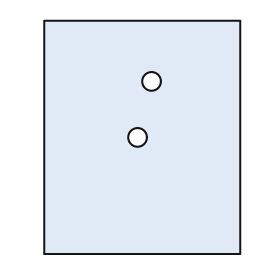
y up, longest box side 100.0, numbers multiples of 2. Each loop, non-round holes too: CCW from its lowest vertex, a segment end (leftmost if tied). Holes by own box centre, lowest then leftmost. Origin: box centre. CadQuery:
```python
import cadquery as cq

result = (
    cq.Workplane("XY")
    .moveTo(-42.0, -50.0)
    .lineTo(42.0, -50.0)
    .lineTo(42.0, 50.0)
    .lineTo(-42.0, 50.0)
    .close()
    .moveTo(-2.0, 0.0)
    .circle(4.0)
    .moveTo(4.0, 24.0)
    .circle(4.0)
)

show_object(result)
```